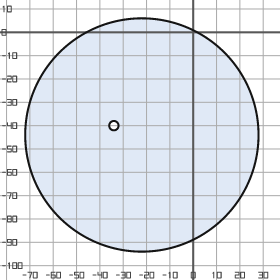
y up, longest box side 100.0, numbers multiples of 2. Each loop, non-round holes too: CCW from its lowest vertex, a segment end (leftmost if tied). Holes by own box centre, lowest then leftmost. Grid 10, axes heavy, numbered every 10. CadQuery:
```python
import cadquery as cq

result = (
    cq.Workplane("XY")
    .moveTo(-22.0, -44.0)
    .circle(50.0)
    .moveTo(-34.0, -40.0)
    .circle(2.0)
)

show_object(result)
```